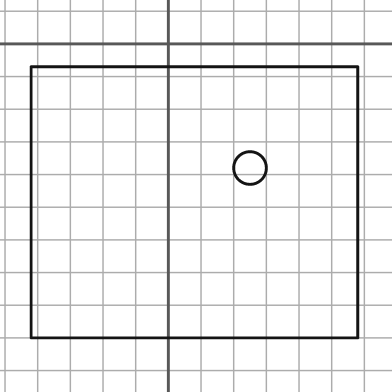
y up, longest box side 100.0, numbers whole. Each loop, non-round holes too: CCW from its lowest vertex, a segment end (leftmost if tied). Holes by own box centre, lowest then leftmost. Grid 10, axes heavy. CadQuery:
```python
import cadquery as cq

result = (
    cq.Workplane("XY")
    .moveTo(-42.0, -90.0)
    .lineTo(58.0, -90.0)
    .lineTo(58.0, -7.0)
    .lineTo(-42.0, -7.0)
    .close()
    .moveTo(25.0, -38.0)
    .circle(5.0)
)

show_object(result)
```